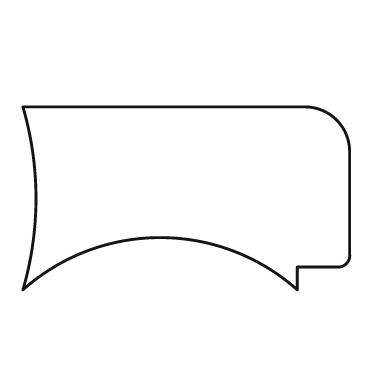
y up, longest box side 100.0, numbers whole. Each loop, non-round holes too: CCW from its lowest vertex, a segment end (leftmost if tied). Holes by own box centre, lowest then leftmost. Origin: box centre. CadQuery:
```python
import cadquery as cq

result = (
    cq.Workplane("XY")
    .moveTo(-50.0, -28.0)
    .threePointArc((-8.0, -12.0), (34.0, -28.0))
    .lineTo(34.0, -21.0)
    .lineTo(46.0, -21.0)
    .threePointArc((49.0, -20.0), (50.0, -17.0))
    .lineTo(50.0, 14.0)
    .threePointArc((46.0, 24.0), (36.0, 28.0))
    .lineTo(-50.0, 28.0)
    .threePointArc((-46.0, 0.0), (-50.0, -28.0))
    .close()
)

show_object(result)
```